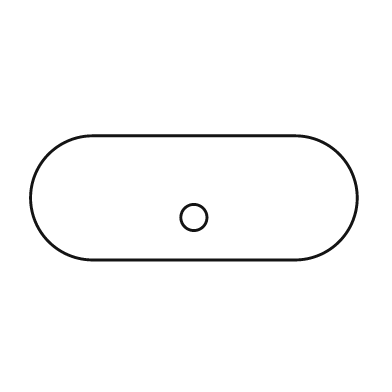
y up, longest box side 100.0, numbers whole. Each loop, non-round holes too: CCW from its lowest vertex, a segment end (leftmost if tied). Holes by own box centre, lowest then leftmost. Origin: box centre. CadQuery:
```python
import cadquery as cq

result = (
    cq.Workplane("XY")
    .moveTo(-31.0, -19.0)
    .lineTo(31.0, -19.0)
    .threePointArc((50.0, 0.0), (31.0, 19.0))
    .lineTo(-31.0, 19.0)
    .threePointArc((-50.0, 0.0), (-31.0, -19.0))
    .close()
    .moveTo(0.0, -6.0)
    .circle(4.0)
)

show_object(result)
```